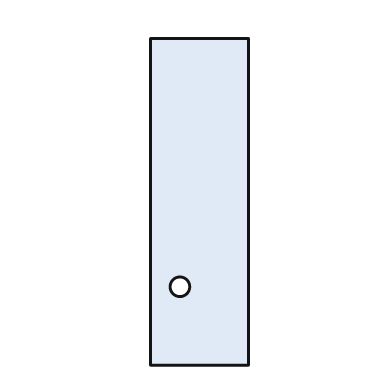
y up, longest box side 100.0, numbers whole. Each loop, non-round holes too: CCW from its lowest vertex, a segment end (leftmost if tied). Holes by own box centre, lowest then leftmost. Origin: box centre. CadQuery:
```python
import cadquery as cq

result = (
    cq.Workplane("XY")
    .moveTo(-15.0, -50.0)
    .lineTo(15.0, -50.0)
    .lineTo(15.0, 50.0)
    .lineTo(-15.0, 50.0)
    .close()
    .moveTo(-6.0, -26.0)
    .circle(3.0)
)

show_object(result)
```